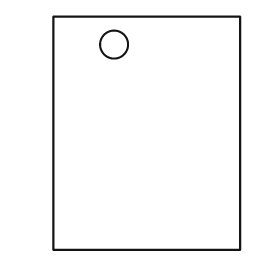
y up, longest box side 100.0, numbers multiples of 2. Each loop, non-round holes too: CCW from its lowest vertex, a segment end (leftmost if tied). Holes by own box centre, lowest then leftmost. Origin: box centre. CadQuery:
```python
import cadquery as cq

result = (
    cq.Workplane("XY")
    .moveTo(-40.0, -50.0)
    .lineTo(40.0, -50.0)
    .lineTo(40.0, 50.0)
    .lineTo(-40.0, 50.0)
    .close()
    .moveTo(-14.0, 38.0)
    .circle(6.0)
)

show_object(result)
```